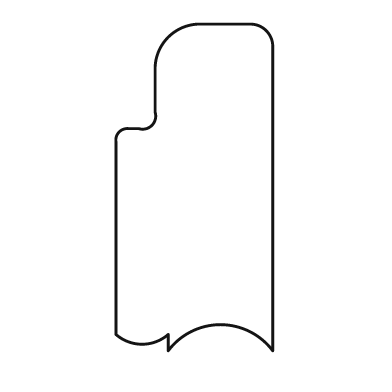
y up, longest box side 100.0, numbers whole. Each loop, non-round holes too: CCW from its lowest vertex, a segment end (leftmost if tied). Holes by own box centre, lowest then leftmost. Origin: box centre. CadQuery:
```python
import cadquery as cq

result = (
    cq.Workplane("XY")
    .moveTo(-8.0, -50.0)
    .threePointArc((8.0, -42.0), (24.0, -50.0))
    .lineTo(24.0, 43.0)
    .threePointArc((22.0, 48.0), (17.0, 50.0))
    .lineTo(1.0, 50.0)
    .threePointArc((-8.0, 46.0), (-12.0, 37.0))
    .lineTo(-12.0, 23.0)
    .threePointArc((-13.0, 19.0), (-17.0, 18.0))
    .lineTo(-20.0, 18.0)
    .threePointArc((-23.0, 17.0), (-24.0, 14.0))
    .lineTo(-24.0, -45.0)
    .threePointArc((-16.0, -48.0), (-8.0, -45.0))
    .close()
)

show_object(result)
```